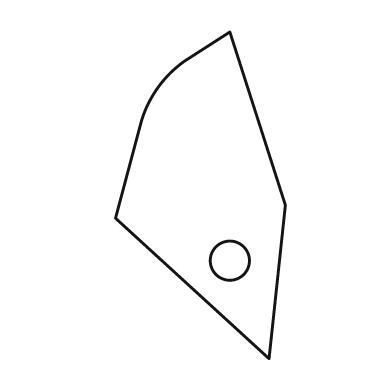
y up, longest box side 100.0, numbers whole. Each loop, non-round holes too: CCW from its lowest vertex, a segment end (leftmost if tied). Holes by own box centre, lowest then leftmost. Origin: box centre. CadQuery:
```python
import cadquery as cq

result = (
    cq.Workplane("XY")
    .moveTo(21.0, -50.0)
    .lineTo(26.0, -3.0)
    .lineTo(9.0, 50.0)
    .lineTo(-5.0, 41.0)
    .threePointArc((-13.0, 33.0), (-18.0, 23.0))
    .lineTo(-26.0, -7.0)
    .close()
    .moveTo(9.0, -20.0)
    .circle(6.0)
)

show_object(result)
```